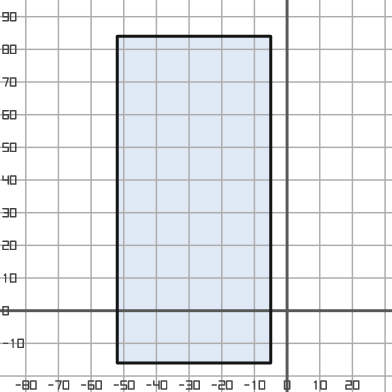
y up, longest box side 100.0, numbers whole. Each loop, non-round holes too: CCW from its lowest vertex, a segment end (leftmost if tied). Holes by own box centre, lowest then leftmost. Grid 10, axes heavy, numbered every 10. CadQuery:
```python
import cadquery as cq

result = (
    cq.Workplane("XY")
    .moveTo(-52.0, -16.0)
    .lineTo(-5.0, -16.0)
    .lineTo(-5.0, 84.0)
    .lineTo(-52.0, 84.0)
    .close()
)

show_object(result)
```